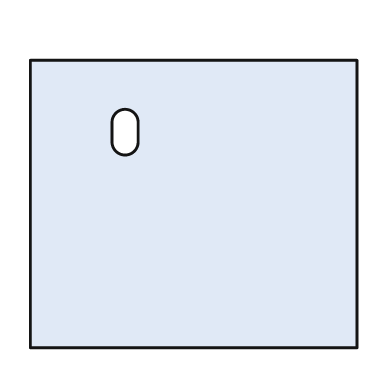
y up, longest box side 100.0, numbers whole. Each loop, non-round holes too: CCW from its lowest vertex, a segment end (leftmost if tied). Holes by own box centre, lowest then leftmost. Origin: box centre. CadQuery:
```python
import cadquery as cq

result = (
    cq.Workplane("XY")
    .moveTo(-50.0, -44.0)
    .lineTo(50.0, -44.0)
    .lineTo(50.0, 44.0)
    .lineTo(-50.0, 44.0)
    .close()
    .moveTo(-25.0, 19.0)
    .threePointArc((-21.0, 15.0), (-17.0, 19.0))
    .lineTo(-17.0, 25.0)
    .threePointArc((-21.0, 29.0), (-25.0, 25.0))
    .close()
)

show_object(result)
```